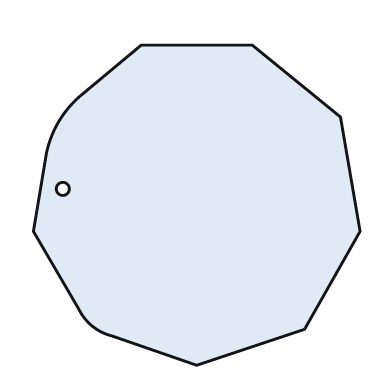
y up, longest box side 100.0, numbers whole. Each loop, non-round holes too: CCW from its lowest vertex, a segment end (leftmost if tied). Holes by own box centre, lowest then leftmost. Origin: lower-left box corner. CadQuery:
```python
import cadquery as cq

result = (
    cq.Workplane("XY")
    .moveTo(50.0, 0.0)
    .lineTo(83.0, 11.0)
    .lineTo(100.0, 41.0)
    .lineTo(94.0, 76.0)
    .lineTo(67.0, 98.0)
    .lineTo(33.0, 98.0)
    .lineTo(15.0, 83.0)
    .threePointArc((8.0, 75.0), (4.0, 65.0))
    .lineTo(0.0, 41.0)
    .lineTo(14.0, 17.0)
    .threePointArc((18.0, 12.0), (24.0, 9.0))
    .close()
    .moveTo(9.0, 54.0)
    .circle(2.0)
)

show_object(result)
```